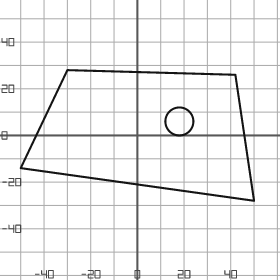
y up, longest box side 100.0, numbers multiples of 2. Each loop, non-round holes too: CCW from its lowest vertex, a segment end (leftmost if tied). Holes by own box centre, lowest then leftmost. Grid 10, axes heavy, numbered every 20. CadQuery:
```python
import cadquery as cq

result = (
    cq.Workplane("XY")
    .moveTo(50.0, -28.0)
    .lineTo(42.0, 26.0)
    .lineTo(-30.0, 28.0)
    .lineTo(-50.0, -14.0)
    .close()
    .moveTo(18.0, 6.0)
    .circle(6.0)
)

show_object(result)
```